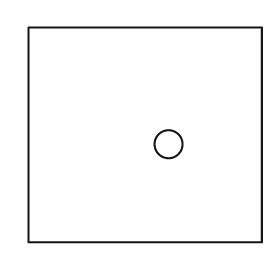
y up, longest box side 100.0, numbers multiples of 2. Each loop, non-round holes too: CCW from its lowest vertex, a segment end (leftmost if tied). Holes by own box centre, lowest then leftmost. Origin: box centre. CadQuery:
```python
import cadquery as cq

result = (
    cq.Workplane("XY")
    .moveTo(-50.0, -46.0)
    .lineTo(50.0, -46.0)
    .lineTo(50.0, 46.0)
    .lineTo(-50.0, 46.0)
    .close()
    .moveTo(10.0, -4.0)
    .circle(6.0)
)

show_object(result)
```